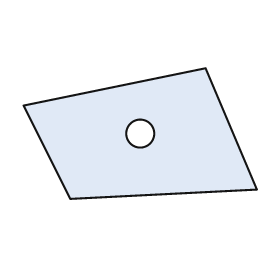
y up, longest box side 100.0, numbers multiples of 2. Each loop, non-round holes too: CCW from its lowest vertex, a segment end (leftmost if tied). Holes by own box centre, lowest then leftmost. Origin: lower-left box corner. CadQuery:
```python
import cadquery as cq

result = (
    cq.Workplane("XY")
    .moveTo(20.0, 0.0)
    .lineTo(100.0, 4.0)
    .lineTo(78.0, 56.0)
    .lineTo(0.0, 40.0)
    .close()
    .moveTo(50.0, 28.0)
    .circle(6.0)
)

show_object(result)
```